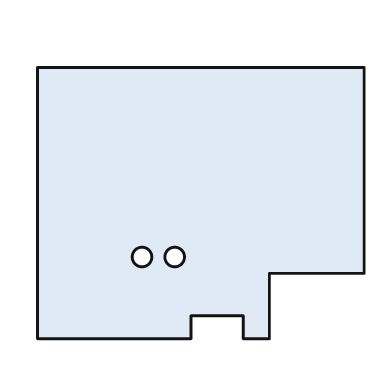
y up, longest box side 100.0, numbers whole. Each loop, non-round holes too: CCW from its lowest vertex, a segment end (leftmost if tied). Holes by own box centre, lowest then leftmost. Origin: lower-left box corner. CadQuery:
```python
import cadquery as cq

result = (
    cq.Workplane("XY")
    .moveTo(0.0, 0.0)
    .lineTo(47.0, 0.0)
    .lineTo(47.0, 7.0)
    .lineTo(63.0, 7.0)
    .lineTo(63.0, 0.0)
    .lineTo(71.0, 0.0)
    .lineTo(71.0, 20.0)
    .lineTo(100.0, 20.0)
    .lineTo(100.0, 83.0)
    .lineTo(0.0, 83.0)
    .close()
    .moveTo(32.0, 25.0)
    .circle(3.0)
    .moveTo(42.0, 25.0)
    .circle(3.0)
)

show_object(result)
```